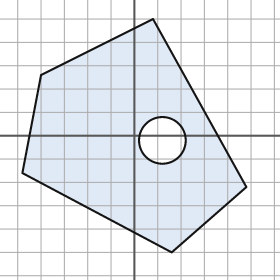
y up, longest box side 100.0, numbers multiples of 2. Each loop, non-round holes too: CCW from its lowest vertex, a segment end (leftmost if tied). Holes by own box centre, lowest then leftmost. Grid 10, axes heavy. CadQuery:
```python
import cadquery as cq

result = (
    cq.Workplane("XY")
    .moveTo(16.0, -50.0)
    .lineTo(48.0, -22.0)
    .lineTo(8.0, 50.0)
    .lineTo(-40.0, 26.0)
    .lineTo(-48.0, -16.0)
    .close()
    .moveTo(12.0, -2.0)
    .circle(10.0)
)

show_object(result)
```